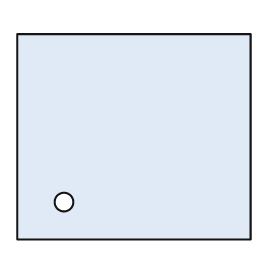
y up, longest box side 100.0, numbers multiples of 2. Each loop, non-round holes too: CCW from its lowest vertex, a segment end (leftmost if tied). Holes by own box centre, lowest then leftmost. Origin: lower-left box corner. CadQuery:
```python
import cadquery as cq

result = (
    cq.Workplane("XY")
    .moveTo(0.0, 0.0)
    .lineTo(100.0, 0.0)
    .lineTo(100.0, 88.0)
    .lineTo(0.0, 88.0)
    .close()
    .moveTo(20.0, 16.0)
    .circle(4.0)
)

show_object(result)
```